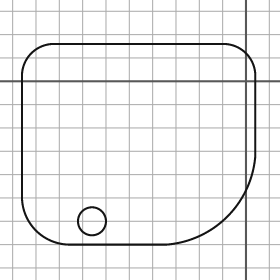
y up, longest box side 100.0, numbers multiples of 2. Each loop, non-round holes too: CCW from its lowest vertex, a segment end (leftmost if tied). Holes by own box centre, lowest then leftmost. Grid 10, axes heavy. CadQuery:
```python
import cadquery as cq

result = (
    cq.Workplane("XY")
    .moveTo(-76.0, -70.0)
    .lineTo(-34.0, -70.0)
    .threePointArc((-8.0, -58.0), (4.0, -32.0))
    .lineTo(4.0, 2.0)
    .threePointArc((0.0, 12.0), (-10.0, 16.0))
    .lineTo(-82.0, 16.0)
    .threePointArc((-92.0, 12.0), (-96.0, 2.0))
    .lineTo(-96.0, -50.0)
    .threePointArc((-90.0, -64.0), (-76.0, -70.0))
    .close()
    .moveTo(-66.0, -60.0)
    .circle(6.0)
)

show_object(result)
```